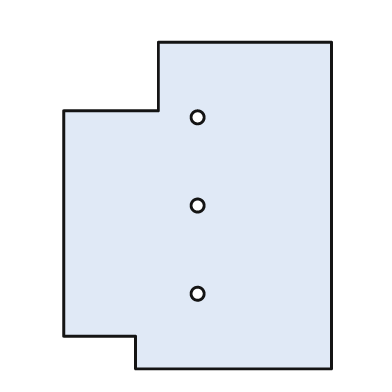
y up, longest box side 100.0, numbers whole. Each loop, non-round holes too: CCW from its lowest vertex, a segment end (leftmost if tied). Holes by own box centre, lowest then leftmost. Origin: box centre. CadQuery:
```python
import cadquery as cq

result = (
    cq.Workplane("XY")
    .moveTo(-19.0, -50.0)
    .lineTo(41.0, -50.0)
    .lineTo(41.0, 50.0)
    .lineTo(-12.0, 50.0)
    .lineTo(-12.0, 29.0)
    .lineTo(-41.0, 29.0)
    .lineTo(-41.0, -40.0)
    .lineTo(-19.0, -40.0)
    .close()
    .moveTo(0.0, -27.0)
    .circle(2.0)
    .moveTo(0.0, 0.0)
    .circle(2.0)
    .moveTo(0.0, 27.0)
    .circle(2.0)
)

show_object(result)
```